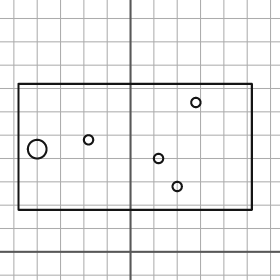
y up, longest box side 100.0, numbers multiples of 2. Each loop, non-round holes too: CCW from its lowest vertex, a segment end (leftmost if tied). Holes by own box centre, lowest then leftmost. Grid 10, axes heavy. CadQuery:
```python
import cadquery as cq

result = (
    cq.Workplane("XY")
    .moveTo(-48.0, 18.0)
    .lineTo(52.0, 18.0)
    .lineTo(52.0, 72.0)
    .lineTo(-48.0, 72.0)
    .close()
    .moveTo(20.0, 28.0)
    .circle(2.0)
    .moveTo(12.0, 40.0)
    .circle(2.0)
    .moveTo(-40.0, 44.0)
    .circle(4.0)
    .moveTo(-18.0, 48.0)
    .circle(2.0)
    .moveTo(28.0, 64.0)
    .circle(2.0)
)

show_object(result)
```